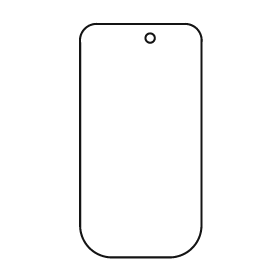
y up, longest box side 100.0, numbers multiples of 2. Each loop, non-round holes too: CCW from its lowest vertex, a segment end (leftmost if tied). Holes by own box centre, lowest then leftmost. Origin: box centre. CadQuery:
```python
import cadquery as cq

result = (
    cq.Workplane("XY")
    .moveTo(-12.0, -50.0)
    .lineTo(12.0, -50.0)
    .threePointArc((22.0, -46.0), (26.0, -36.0))
    .lineTo(26.0, 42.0)
    .threePointArc((24.0, 48.0), (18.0, 50.0))
    .lineTo(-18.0, 50.0)
    .threePointArc((-24.0, 48.0), (-26.0, 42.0))
    .lineTo(-26.0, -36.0)
    .threePointArc((-22.0, -46.0), (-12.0, -50.0))
    .close()
    .moveTo(4.0, 44.0)
    .circle(2.0)
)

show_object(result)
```